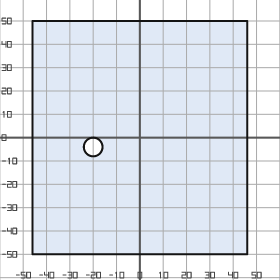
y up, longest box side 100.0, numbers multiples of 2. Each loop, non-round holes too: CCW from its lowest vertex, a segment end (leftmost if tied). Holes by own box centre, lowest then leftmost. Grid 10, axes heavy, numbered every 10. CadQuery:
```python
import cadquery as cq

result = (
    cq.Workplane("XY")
    .moveTo(-46.0, -50.0)
    .lineTo(46.0, -50.0)
    .lineTo(46.0, 50.0)
    .lineTo(-46.0, 50.0)
    .close()
    .moveTo(-20.0, -4.0)
    .circle(4.0)
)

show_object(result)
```